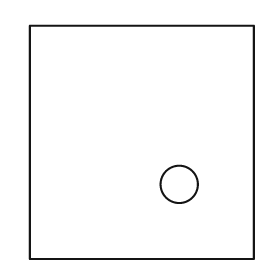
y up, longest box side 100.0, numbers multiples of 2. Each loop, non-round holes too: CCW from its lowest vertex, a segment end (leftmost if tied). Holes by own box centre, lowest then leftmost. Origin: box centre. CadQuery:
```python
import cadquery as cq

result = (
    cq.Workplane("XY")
    .moveTo(-48.0, -50.0)
    .lineTo(48.0, -50.0)
    .lineTo(48.0, 50.0)
    .lineTo(-48.0, 50.0)
    .close()
    .moveTo(16.0, -18.0)
    .circle(8.0)
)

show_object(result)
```